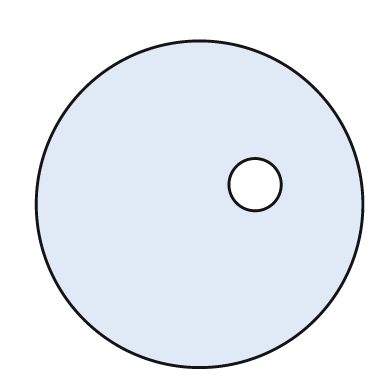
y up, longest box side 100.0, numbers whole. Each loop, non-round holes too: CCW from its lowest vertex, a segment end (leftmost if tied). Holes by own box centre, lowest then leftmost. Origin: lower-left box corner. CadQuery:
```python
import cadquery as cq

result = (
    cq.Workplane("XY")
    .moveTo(50.0, 50.0)
    .circle(50.0)
    .moveTo(67.0, 56.0)
    .circle(8.0)
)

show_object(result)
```